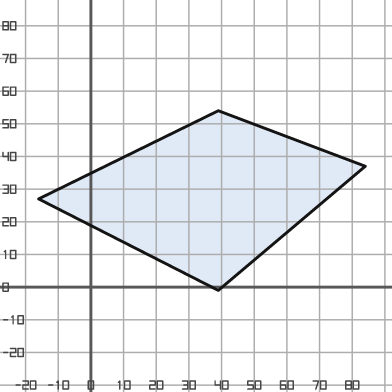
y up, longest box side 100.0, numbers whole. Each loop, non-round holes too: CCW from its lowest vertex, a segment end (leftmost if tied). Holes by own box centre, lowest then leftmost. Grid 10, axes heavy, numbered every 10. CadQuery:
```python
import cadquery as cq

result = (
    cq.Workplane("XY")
    .moveTo(39.0, -1.0)
    .lineTo(84.0, 37.0)
    .lineTo(39.0, 54.0)
    .lineTo(-16.0, 27.0)
    .close()
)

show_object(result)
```